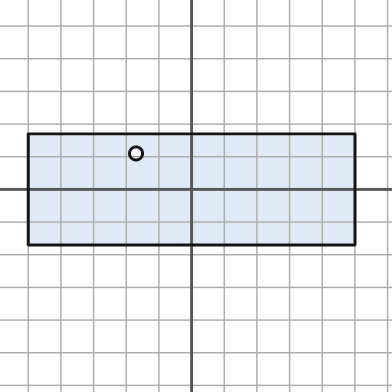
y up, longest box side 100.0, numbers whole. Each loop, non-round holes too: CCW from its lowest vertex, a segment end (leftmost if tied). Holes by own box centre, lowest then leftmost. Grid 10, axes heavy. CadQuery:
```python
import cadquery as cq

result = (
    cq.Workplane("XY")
    .moveTo(-50.0, -17.0)
    .lineTo(50.0, -17.0)
    .lineTo(50.0, 17.0)
    .lineTo(-50.0, 17.0)
    .close()
    .moveTo(-17.0, 11.0)
    .circle(2.0)
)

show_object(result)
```